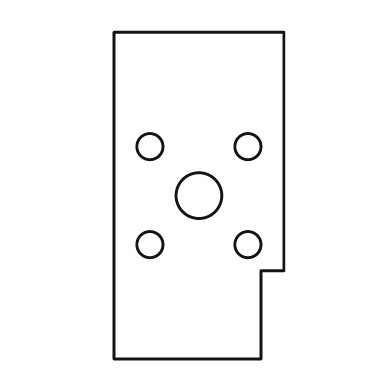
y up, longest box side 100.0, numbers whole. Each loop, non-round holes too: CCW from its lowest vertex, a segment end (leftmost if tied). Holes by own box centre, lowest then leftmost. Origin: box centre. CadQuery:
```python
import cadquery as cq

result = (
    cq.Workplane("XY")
    .moveTo(-26.0, -50.0)
    .lineTo(19.0, -50.0)
    .lineTo(19.0, -23.0)
    .lineTo(26.0, -23.0)
    .lineTo(26.0, 50.0)
    .lineTo(-26.0, 50.0)
    .close()
    .moveTo(-15.0, -15.0)
    .circle(4.0)
    .moveTo(15.0, -15.0)
    .circle(4.0)
    .moveTo(0.0, 0.0)
    .circle(7.0)
    .moveTo(-15.0, 15.0)
    .circle(4.0)
    .moveTo(15.0, 15.0)
    .circle(4.0)
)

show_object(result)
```